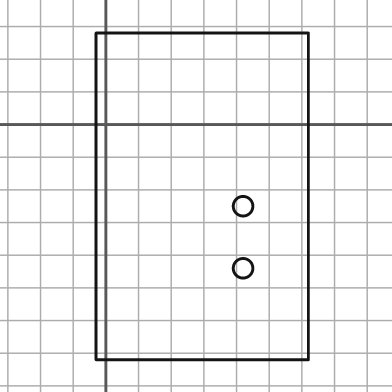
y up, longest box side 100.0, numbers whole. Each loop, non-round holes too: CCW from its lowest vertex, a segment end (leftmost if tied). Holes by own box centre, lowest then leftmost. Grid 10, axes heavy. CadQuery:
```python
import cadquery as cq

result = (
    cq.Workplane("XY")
    .moveTo(-3.0, -72.0)
    .lineTo(62.0, -72.0)
    .lineTo(62.0, 28.0)
    .lineTo(-3.0, 28.0)
    .close()
    .moveTo(42.0, -44.0)
    .circle(3.0)
    .moveTo(42.0, -25.0)
    .circle(3.0)
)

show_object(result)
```